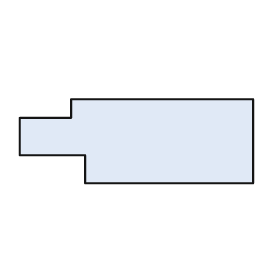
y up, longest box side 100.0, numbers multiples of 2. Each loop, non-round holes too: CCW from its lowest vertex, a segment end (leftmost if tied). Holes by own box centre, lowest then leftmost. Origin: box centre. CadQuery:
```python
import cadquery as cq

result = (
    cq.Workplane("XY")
    .moveTo(-22.0, -18.0)
    .lineTo(50.0, -18.0)
    .lineTo(50.0, 18.0)
    .lineTo(-28.0, 18.0)
    .lineTo(-28.0, 10.0)
    .lineTo(-50.0, 10.0)
    .lineTo(-50.0, -6.0)
    .lineTo(-22.0, -6.0)
    .close()
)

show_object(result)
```